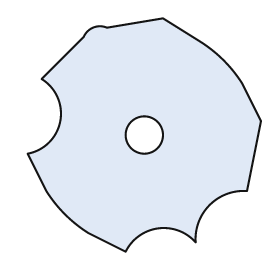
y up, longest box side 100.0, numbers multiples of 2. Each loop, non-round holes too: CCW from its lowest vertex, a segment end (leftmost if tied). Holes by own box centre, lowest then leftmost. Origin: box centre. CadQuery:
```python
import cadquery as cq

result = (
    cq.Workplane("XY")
    .moveTo(-8.0, -50.0)
    .threePointArc((6.0, -40.0), (22.0, -46.0))
    .threePointArc((28.0, -30.0), (44.0, -24.0))
    .lineTo(50.0, 6.0)
    .lineTo(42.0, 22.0)
    .threePointArc((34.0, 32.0), (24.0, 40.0))
    .lineTo(8.0, 50.0)
    .lineTo(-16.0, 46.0)
    .threePointArc((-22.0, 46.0), (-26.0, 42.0))
    .lineTo(-44.0, 24.0)
    .threePointArc((-36.0, 6.0), (-50.0, -8.0))
    .lineTo(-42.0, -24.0)
    .threePointArc((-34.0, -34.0), (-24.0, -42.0))
    .close()
    .moveTo(0.0, 0.0)
    .circle(8.0)
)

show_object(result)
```